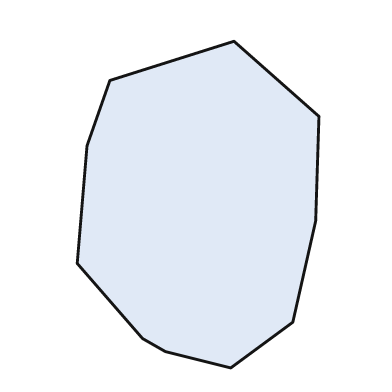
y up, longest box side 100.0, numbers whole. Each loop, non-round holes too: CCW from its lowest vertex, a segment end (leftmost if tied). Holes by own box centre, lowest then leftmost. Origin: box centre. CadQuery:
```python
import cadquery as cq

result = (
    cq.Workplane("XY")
    .moveTo(10.0, -50.0)
    .lineTo(29.0, -36.0)
    .lineTo(36.0, -5.0)
    .lineTo(37.0, 27.0)
    .lineTo(11.0, 50.0)
    .lineTo(-27.0, 38.0)
    .lineTo(-34.0, 18.0)
    .lineTo(-37.0, -18.0)
    .lineTo(-17.0, -41.0)
    .lineTo(-10.0, -45.0)
    .close()
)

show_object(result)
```